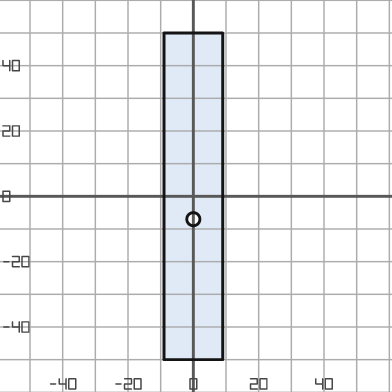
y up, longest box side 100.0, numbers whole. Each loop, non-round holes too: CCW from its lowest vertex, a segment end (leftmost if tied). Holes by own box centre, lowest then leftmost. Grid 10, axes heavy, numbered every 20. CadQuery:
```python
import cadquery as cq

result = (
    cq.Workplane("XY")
    .moveTo(-9.0, -50.0)
    .lineTo(9.0, -50.0)
    .lineTo(9.0, 50.0)
    .lineTo(-9.0, 50.0)
    .close()
    .moveTo(0.0, -7.0)
    .circle(2.0)
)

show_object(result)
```